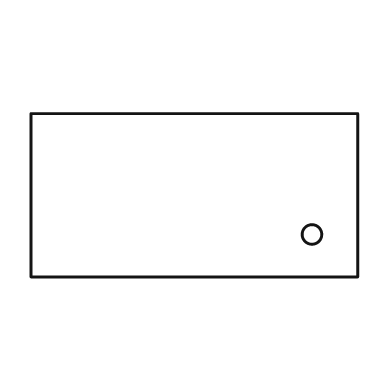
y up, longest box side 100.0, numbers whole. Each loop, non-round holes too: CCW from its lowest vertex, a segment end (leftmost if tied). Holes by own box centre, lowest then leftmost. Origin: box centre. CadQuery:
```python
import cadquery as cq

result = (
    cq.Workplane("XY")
    .moveTo(-50.0, -25.0)
    .lineTo(50.0, -25.0)
    .lineTo(50.0, 25.0)
    .lineTo(-50.0, 25.0)
    .close()
    .moveTo(36.0, -12.0)
    .circle(3.0)
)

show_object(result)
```